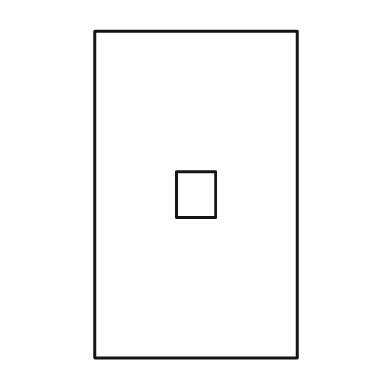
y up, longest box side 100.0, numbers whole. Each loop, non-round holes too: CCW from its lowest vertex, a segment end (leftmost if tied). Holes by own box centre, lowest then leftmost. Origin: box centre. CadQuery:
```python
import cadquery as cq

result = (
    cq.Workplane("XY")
    .moveTo(-31.0, -50.0)
    .lineTo(31.0, -50.0)
    .lineTo(31.0, 50.0)
    .lineTo(-31.0, 50.0)
    .close()
    .moveTo(-6.0, -7.0)
    .lineTo(6.0, -7.0)
    .lineTo(6.0, 7.0)
    .lineTo(-6.0, 7.0)
    .close()
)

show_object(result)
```